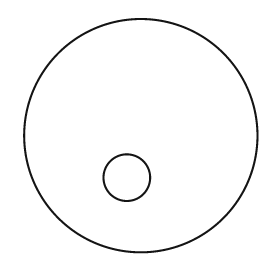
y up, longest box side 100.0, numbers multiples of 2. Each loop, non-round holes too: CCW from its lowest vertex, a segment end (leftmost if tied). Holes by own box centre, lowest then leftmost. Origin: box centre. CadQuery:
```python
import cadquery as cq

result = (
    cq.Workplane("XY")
    .moveTo(0.0, 0.0)
    .circle(50.0)
    .moveTo(-6.0, -18.0)
    .circle(10.0)
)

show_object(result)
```